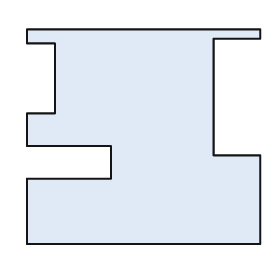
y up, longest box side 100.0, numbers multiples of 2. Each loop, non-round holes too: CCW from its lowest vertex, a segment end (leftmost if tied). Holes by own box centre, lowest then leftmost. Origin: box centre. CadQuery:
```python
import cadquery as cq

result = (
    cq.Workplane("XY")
    .moveTo(-50.0, -46.0)
    .lineTo(50.0, -46.0)
    .lineTo(50.0, -8.0)
    .lineTo(30.0, -8.0)
    .lineTo(30.0, 42.0)
    .lineTo(50.0, 42.0)
    .lineTo(50.0, 46.0)
    .lineTo(-50.0, 46.0)
    .lineTo(-50.0, 40.0)
    .lineTo(-38.0, 40.0)
    .lineTo(-38.0, 10.0)
    .lineTo(-50.0, 10.0)
    .lineTo(-50.0, -4.0)
    .lineTo(-14.0, -4.0)
    .lineTo(-14.0, -18.0)
    .lineTo(-50.0, -18.0)
    .close()
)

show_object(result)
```